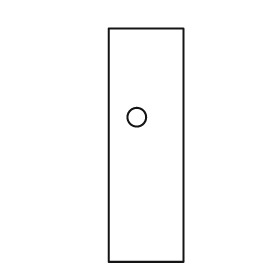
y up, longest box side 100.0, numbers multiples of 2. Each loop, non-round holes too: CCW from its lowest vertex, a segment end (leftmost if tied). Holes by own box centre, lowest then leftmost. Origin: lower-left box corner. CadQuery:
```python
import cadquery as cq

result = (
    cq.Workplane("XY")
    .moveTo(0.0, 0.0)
    .lineTo(32.0, 0.0)
    .lineTo(32.0, 100.0)
    .lineTo(0.0, 100.0)
    .close()
    .moveTo(12.0, 62.0)
    .circle(4.0)
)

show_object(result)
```